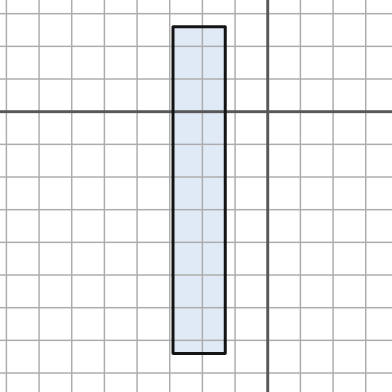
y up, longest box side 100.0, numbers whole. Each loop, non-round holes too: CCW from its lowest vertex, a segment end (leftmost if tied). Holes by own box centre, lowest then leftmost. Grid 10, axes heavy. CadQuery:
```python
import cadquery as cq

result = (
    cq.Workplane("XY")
    .moveTo(-29.0, -74.0)
    .lineTo(-13.0, -74.0)
    .lineTo(-13.0, 26.0)
    .lineTo(-29.0, 26.0)
    .close()
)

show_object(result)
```